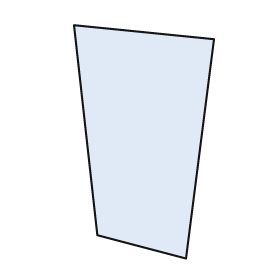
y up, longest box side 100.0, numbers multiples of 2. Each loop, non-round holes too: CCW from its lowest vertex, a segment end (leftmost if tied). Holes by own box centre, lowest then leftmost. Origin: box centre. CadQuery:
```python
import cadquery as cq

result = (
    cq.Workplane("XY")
    .moveTo(18.0, -50.0)
    .lineTo(30.0, 44.0)
    .lineTo(-30.0, 50.0)
    .lineTo(-20.0, -40.0)
    .close()
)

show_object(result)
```